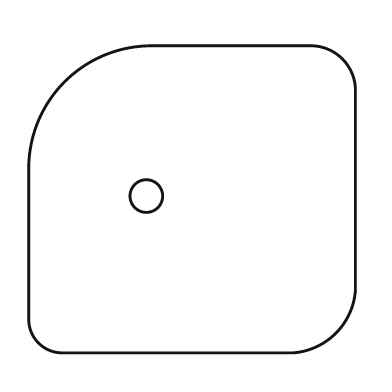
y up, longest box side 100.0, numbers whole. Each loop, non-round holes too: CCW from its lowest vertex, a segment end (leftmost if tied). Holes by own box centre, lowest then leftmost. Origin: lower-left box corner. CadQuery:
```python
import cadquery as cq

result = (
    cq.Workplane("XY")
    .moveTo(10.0, 0.0)
    .lineTo(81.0, 0.0)
    .threePointArc((94.0, 6.0), (100.0, 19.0))
    .lineTo(100.0, 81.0)
    .threePointArc((96.0, 90.0), (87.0, 94.0))
    .lineTo(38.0, 94.0)
    .threePointArc((11.0, 83.0), (0.0, 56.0))
    .lineTo(0.0, 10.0)
    .threePointArc((3.0, 3.0), (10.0, 0.0))
    .close()
    .moveTo(36.0, 48.0)
    .circle(5.0)
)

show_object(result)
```